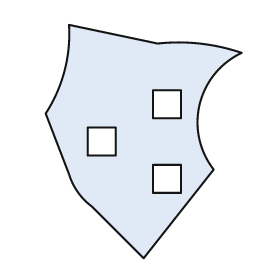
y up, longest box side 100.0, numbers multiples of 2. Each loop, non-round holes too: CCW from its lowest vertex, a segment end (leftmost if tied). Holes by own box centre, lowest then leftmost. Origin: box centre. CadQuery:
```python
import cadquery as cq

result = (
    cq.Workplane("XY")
    .moveTo(0.0, -50.0)
    .lineTo(30.0, -12.0)
    .threePointArc((24.0, 16.0), (42.0, 38.0))
    .threePointArc((24.0, 42.0), (6.0, 42.0))
    .lineTo(-32.0, 50.0)
    .threePointArc((-34.0, 30.0), (-42.0, 12.0))
    .lineTo(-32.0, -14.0)
    .threePointArc((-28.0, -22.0), (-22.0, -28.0))
    .close()
    .moveTo(4.0, -22.0)
    .lineTo(16.0, -22.0)
    .lineTo(16.0, -10.0)
    .lineTo(4.0, -10.0)
    .close()
    .moveTo(-24.0, -6.0)
    .lineTo(-12.0, -6.0)
    .lineTo(-12.0, 6.0)
    .lineTo(-24.0, 6.0)
    .close()
    .moveTo(4.0, 10.0)
    .lineTo(16.0, 10.0)
    .lineTo(16.0, 22.0)
    .lineTo(4.0, 22.0)
    .close()
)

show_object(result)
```